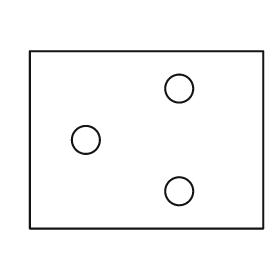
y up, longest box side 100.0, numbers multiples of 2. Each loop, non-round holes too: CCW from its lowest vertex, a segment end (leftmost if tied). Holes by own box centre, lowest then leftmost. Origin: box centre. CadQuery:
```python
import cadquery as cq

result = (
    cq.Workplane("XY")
    .moveTo(-50.0, -38.0)
    .lineTo(50.0, -38.0)
    .lineTo(50.0, 38.0)
    .lineTo(-50.0, 38.0)
    .close()
    .moveTo(14.0, -22.0)
    .circle(6.0)
    .moveTo(-26.0, 0.0)
    .circle(6.0)
    .moveTo(14.0, 22.0)
    .circle(6.0)
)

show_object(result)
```